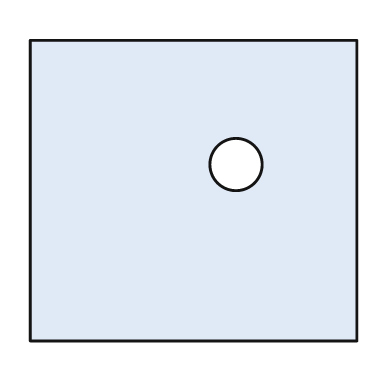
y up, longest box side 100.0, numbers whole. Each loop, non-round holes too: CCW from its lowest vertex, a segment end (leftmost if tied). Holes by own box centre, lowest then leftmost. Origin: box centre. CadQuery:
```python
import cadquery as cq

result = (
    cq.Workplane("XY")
    .moveTo(-50.0, -46.0)
    .lineTo(50.0, -46.0)
    .lineTo(50.0, 46.0)
    .lineTo(-50.0, 46.0)
    .close()
    .moveTo(13.0, 8.0)
    .circle(8.0)
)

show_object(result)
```